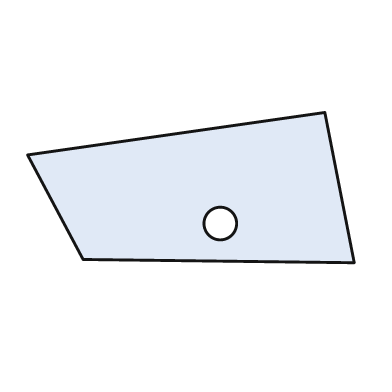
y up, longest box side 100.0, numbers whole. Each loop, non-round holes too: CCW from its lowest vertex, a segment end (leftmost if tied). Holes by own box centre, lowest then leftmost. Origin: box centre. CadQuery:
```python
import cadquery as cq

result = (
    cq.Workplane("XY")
    .moveTo(50.0, -23.0)
    .lineTo(41.0, 23.0)
    .lineTo(-50.0, 10.0)
    .lineTo(-33.0, -22.0)
    .close()
    .moveTo(9.0, -11.0)
    .circle(5.0)
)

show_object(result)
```